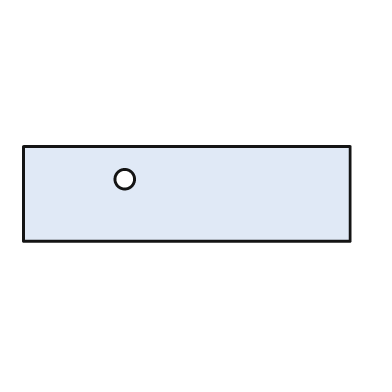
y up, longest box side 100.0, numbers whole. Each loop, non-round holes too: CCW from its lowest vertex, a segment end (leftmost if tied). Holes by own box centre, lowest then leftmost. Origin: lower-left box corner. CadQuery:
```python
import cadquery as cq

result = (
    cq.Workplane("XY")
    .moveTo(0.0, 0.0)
    .lineTo(100.0, 0.0)
    .lineTo(100.0, 29.0)
    .lineTo(0.0, 29.0)
    .close()
    .moveTo(31.0, 19.0)
    .circle(3.0)
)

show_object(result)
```